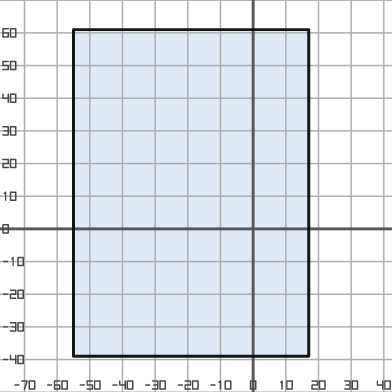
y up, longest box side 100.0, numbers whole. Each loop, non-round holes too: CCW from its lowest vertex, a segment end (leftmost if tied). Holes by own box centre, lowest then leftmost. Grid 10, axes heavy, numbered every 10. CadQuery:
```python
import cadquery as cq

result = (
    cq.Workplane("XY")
    .moveTo(-55.0, -39.0)
    .lineTo(17.0, -39.0)
    .lineTo(17.0, 61.0)
    .lineTo(-55.0, 61.0)
    .close()
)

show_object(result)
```